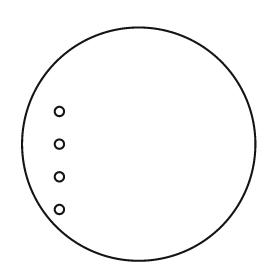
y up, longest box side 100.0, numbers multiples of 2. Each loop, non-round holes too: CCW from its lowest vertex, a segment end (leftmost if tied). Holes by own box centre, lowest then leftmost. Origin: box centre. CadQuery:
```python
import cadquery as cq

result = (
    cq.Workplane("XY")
    .moveTo(0.0, 0.0)
    .circle(50.0)
    .moveTo(-34.0, -28.0)
    .circle(2.0)
    .moveTo(-34.0, -14.0)
    .circle(2.0)
    .moveTo(-34.0, 0.0)
    .circle(2.0)
    .moveTo(-34.0, 14.0)
    .circle(2.0)
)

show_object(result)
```